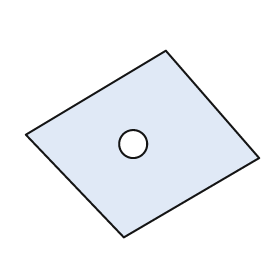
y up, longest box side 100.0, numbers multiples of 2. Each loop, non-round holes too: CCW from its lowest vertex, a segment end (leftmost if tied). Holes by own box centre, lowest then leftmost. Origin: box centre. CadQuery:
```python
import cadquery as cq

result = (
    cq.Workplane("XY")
    .moveTo(-8.0, -40.0)
    .lineTo(50.0, -6.0)
    .lineTo(10.0, 40.0)
    .lineTo(-50.0, 4.0)
    .close()
    .moveTo(-4.0, 0.0)
    .circle(6.0)
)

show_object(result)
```